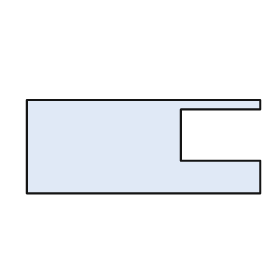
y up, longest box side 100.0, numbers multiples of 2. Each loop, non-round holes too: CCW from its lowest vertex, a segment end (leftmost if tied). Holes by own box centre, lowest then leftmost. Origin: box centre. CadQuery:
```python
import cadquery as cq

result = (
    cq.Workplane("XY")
    .moveTo(-50.0, -20.0)
    .lineTo(50.0, -20.0)
    .lineTo(50.0, -6.0)
    .lineTo(16.0, -6.0)
    .lineTo(16.0, 16.0)
    .lineTo(50.0, 16.0)
    .lineTo(50.0, 20.0)
    .lineTo(-50.0, 20.0)
    .close()
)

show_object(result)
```